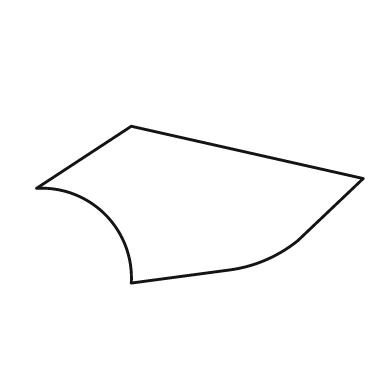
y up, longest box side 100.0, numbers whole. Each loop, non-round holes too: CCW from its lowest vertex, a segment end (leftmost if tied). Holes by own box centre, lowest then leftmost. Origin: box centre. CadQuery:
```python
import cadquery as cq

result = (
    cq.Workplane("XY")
    .moveTo(-21.0, -24.0)
    .lineTo(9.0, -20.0)
    .threePointArc((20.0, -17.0), (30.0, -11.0))
    .lineTo(50.0, 8.0)
    .lineTo(-21.0, 24.0)
    .lineTo(-50.0, 5.0)
    .threePointArc((-29.0, -3.0), (-21.0, -24.0))
    .close()
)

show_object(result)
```